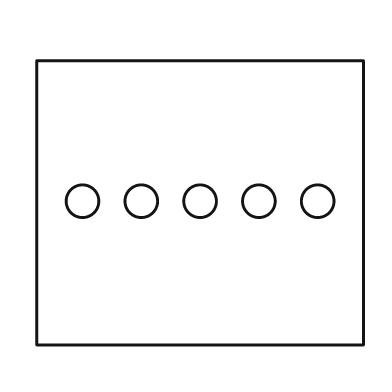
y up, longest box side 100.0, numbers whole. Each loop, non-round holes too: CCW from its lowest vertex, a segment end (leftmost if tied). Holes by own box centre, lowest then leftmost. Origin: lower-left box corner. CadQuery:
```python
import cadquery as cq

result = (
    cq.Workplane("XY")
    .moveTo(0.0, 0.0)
    .lineTo(100.0, 0.0)
    .lineTo(100.0, 87.0)
    .lineTo(0.0, 87.0)
    .close()
    .moveTo(14.0, 44.0)
    .circle(5.0)
    .moveTo(32.0, 44.0)
    .circle(5.0)
    .moveTo(50.0, 44.0)
    .circle(5.0)
    .moveTo(68.0, 44.0)
    .circle(5.0)
    .moveTo(86.0, 44.0)
    .circle(5.0)
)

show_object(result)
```